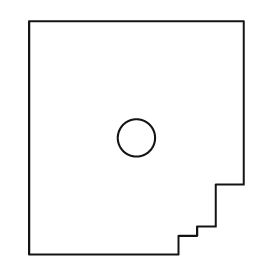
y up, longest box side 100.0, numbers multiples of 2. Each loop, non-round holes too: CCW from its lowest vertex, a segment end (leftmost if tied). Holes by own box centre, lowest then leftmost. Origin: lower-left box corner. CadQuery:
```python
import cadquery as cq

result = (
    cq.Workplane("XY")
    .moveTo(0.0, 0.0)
    .lineTo(64.0, 0.0)
    .lineTo(64.0, 8.0)
    .lineTo(72.0, 8.0)
    .lineTo(72.0, 12.0)
    .lineTo(80.0, 12.0)
    .lineTo(80.0, 30.0)
    .lineTo(92.0, 30.0)
    .lineTo(92.0, 100.0)
    .lineTo(0.0, 100.0)
    .close()
    .moveTo(46.0, 50.0)
    .circle(8.0)
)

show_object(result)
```